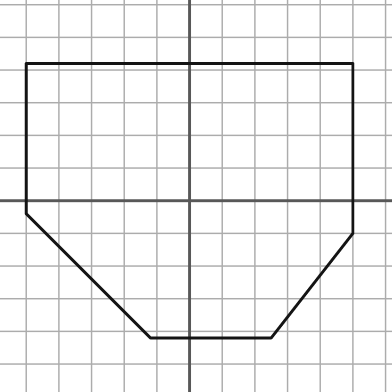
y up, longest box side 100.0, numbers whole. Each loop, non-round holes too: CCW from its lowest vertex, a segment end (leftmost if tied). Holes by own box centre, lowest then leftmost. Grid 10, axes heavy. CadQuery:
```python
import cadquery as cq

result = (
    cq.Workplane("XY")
    .moveTo(-12.0, -42.0)
    .lineTo(25.0, -42.0)
    .lineTo(50.0, -10.0)
    .lineTo(50.0, 42.0)
    .lineTo(-50.0, 42.0)
    .lineTo(-50.0, -4.0)
    .close()
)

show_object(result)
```